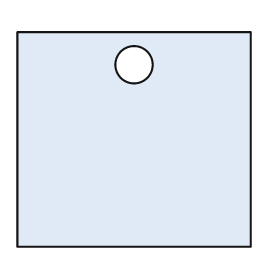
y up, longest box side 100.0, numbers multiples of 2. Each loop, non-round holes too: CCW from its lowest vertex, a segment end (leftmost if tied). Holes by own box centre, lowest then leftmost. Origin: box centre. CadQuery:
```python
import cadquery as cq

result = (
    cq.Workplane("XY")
    .moveTo(-50.0, -46.0)
    .lineTo(50.0, -46.0)
    .lineTo(50.0, 46.0)
    .lineTo(-50.0, 46.0)
    .close()
    .moveTo(0.0, 32.0)
    .circle(8.0)
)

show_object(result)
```